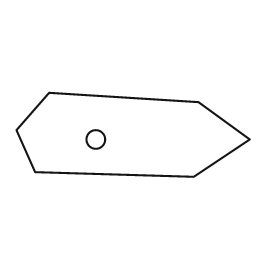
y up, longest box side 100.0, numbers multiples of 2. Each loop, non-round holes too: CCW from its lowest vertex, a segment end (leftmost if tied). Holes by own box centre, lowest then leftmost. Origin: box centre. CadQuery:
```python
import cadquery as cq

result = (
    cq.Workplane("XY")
    .moveTo(26.0, -18.0)
    .lineTo(50.0, -2.0)
    .lineTo(28.0, 14.0)
    .lineTo(-36.0, 18.0)
    .lineTo(-50.0, 2.0)
    .lineTo(-42.0, -16.0)
    .close()
    .moveTo(-16.0, -2.0)
    .circle(4.0)
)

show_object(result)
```